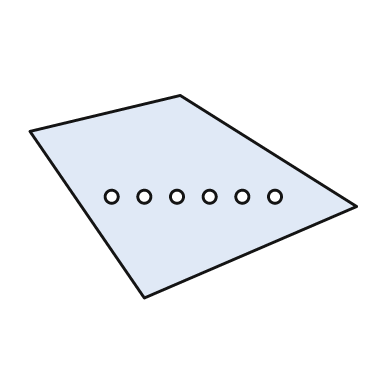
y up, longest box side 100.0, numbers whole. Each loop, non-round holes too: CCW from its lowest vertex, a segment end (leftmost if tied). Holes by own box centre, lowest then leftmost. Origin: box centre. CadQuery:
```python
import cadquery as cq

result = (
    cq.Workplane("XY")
    .moveTo(-15.0, -31.0)
    .lineTo(50.0, -3.0)
    .lineTo(-4.0, 31.0)
    .lineTo(-50.0, 20.0)
    .close()
    .moveTo(-25.0, 0.0)
    .circle(2.0)
    .moveTo(-15.0, 0.0)
    .circle(2.0)
    .moveTo(-5.0, 0.0)
    .circle(2.0)
    .moveTo(5.0, 0.0)
    .circle(2.0)
    .moveTo(15.0, 0.0)
    .circle(2.0)
    .moveTo(25.0, 0.0)
    .circle(2.0)
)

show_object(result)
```